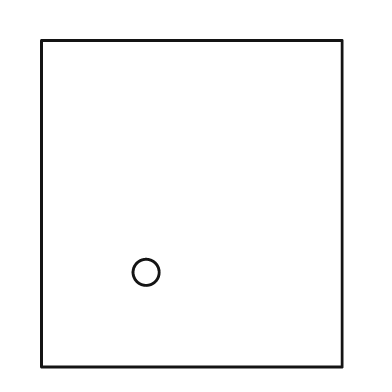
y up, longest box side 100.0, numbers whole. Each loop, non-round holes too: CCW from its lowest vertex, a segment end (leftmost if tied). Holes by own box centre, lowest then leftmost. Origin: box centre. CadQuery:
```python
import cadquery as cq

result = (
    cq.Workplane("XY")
    .moveTo(-46.0, -50.0)
    .lineTo(46.0, -50.0)
    .lineTo(46.0, 50.0)
    .lineTo(-46.0, 50.0)
    .close()
    .moveTo(-14.0, -21.0)
    .circle(4.0)
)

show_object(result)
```